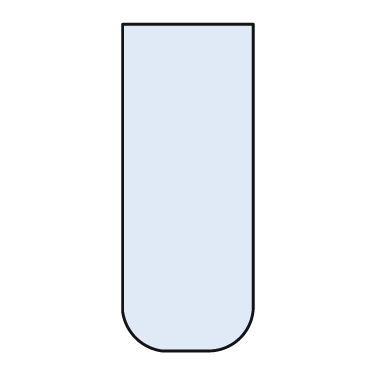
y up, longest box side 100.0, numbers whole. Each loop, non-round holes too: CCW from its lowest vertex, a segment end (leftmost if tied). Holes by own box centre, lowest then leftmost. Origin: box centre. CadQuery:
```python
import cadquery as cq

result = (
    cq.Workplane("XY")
    .moveTo(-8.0, -50.0)
    .lineTo(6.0, -50.0)
    .threePointArc((16.0, -46.0), (20.0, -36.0))
    .lineTo(20.0, 50.0)
    .lineTo(-20.0, 50.0)
    .lineTo(-20.0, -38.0)
    .threePointArc((-16.0, -46.0), (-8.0, -50.0))
    .close()
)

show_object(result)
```